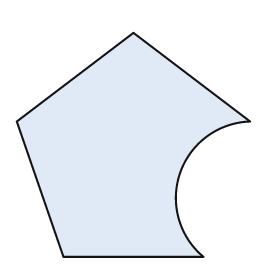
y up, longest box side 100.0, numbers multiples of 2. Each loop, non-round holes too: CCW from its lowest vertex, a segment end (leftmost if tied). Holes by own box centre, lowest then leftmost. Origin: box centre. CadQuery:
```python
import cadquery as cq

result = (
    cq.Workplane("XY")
    .moveTo(-30.0, -48.0)
    .lineTo(30.0, -48.0)
    .threePointArc((20.0, -12.0), (50.0, 10.0))
    .lineTo(0.0, 48.0)
    .lineTo(-50.0, 10.0)
    .close()
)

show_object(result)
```